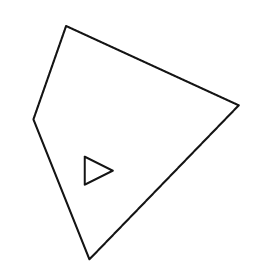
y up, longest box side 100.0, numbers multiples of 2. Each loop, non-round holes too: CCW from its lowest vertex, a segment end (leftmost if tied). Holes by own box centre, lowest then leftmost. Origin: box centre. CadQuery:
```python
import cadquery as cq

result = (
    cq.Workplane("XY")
    .moveTo(-20.0, -50.0)
    .lineTo(44.0, 16.0)
    .lineTo(-30.0, 50.0)
    .lineTo(-44.0, 10.0)
    .close()
    .moveTo(-22.0, -18.0)
    .lineTo(-10.0, -12.0)
    .lineTo(-22.0, -6.0)
    .close()
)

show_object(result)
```